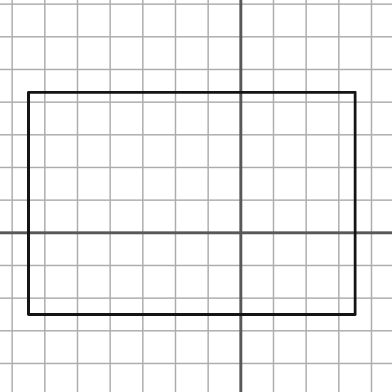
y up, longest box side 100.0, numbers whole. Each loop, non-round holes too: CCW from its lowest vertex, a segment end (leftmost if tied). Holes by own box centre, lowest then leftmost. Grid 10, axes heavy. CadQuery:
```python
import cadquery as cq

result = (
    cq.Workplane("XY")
    .moveTo(-65.0, -25.0)
    .lineTo(35.0, -25.0)
    .lineTo(35.0, 43.0)
    .lineTo(-65.0, 43.0)
    .close()
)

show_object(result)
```